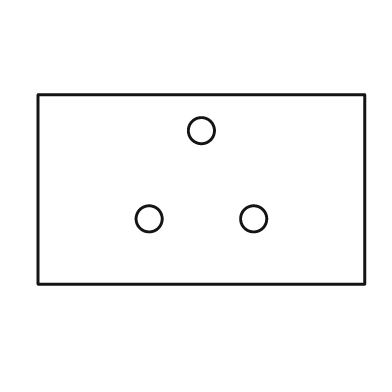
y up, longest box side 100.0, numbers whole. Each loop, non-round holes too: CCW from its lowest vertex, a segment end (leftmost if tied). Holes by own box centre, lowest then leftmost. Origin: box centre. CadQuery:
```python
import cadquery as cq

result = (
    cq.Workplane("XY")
    .moveTo(-50.0, -29.0)
    .lineTo(50.0, -29.0)
    .lineTo(50.0, 29.0)
    .lineTo(-50.0, 29.0)
    .close()
    .moveTo(-16.0, -9.0)
    .circle(4.0)
    .moveTo(16.0, -9.0)
    .circle(4.0)
    .moveTo(0.0, 18.0)
    .circle(4.0)
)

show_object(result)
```